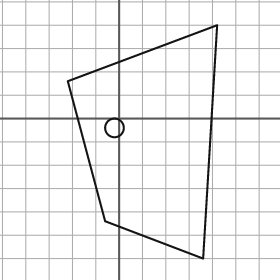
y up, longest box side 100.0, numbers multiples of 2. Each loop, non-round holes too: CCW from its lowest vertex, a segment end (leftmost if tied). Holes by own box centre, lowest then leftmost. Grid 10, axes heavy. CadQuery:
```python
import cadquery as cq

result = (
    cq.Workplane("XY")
    .moveTo(36.0, -60.0)
    .lineTo(42.0, 40.0)
    .lineTo(-22.0, 16.0)
    .lineTo(-6.0, -44.0)
    .close()
    .moveTo(-2.0, -4.0)
    .circle(4.0)
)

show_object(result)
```